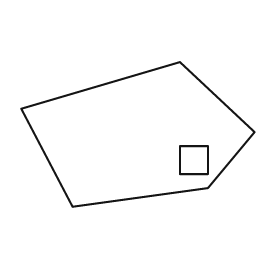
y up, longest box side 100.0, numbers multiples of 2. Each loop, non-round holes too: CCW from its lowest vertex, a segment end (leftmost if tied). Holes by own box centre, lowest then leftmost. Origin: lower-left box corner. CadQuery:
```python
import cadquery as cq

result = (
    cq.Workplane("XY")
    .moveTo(22.0, 0.0)
    .lineTo(80.0, 8.0)
    .lineTo(100.0, 32.0)
    .lineTo(68.0, 62.0)
    .lineTo(0.0, 42.0)
    .close()
    .moveTo(68.0, 14.0)
    .lineTo(80.0, 14.0)
    .lineTo(80.0, 26.0)
    .lineTo(68.0, 26.0)
    .close()
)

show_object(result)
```